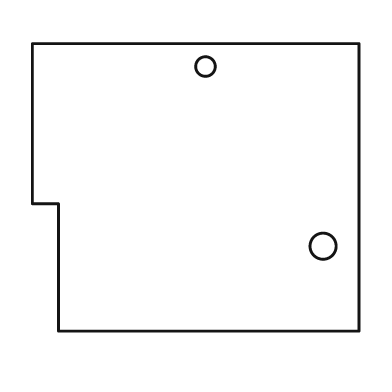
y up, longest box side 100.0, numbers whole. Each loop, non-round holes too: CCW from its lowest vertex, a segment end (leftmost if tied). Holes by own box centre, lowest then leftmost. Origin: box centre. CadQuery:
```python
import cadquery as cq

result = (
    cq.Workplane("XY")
    .moveTo(-42.0, -44.0)
    .lineTo(50.0, -44.0)
    .lineTo(50.0, 44.0)
    .lineTo(-50.0, 44.0)
    .lineTo(-50.0, -5.0)
    .lineTo(-42.0, -5.0)
    .close()
    .moveTo(39.0, -18.0)
    .circle(4.0)
    .moveTo(3.0, 37.0)
    .circle(3.0)
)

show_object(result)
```